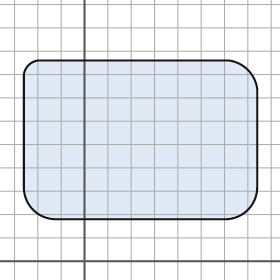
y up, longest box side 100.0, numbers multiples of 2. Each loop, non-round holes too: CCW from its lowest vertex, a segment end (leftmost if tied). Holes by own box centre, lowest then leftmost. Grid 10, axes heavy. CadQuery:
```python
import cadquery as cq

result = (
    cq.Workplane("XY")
    .moveTo(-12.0, 18.0)
    .lineTo(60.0, 18.0)
    .threePointArc((70.0, 22.0), (74.0, 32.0))
    .lineTo(74.0, 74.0)
    .threePointArc((70.0, 82.0), (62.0, 86.0))
    .lineTo(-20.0, 86.0)
    .threePointArc((-24.0, 84.0), (-26.0, 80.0))
    .lineTo(-26.0, 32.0)
    .threePointArc((-22.0, 22.0), (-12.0, 18.0))
    .close()
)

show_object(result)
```